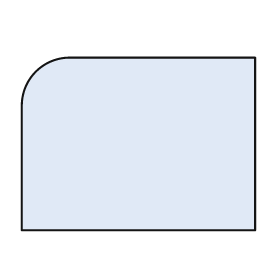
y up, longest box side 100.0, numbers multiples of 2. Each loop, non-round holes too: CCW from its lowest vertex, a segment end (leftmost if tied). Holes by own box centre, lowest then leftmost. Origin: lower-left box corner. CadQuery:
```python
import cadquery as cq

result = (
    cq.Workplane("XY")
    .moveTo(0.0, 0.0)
    .lineTo(100.0, 0.0)
    .lineTo(100.0, 74.0)
    .lineTo(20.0, 74.0)
    .threePointArc((6.0, 68.0), (0.0, 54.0))
    .close()
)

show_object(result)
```